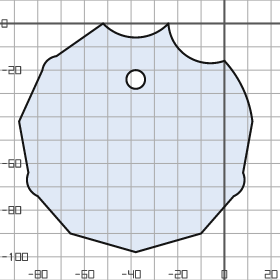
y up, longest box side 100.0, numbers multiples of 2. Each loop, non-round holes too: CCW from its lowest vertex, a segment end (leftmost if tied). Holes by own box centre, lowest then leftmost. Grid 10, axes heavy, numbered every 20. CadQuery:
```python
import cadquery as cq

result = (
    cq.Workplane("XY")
    .moveTo(-38.0, -98.0)
    .lineTo(-10.0, -90.0)
    .lineTo(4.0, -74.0)
    .threePointArc((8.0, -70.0), (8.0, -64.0))
    .lineTo(12.0, -42.0)
    .threePointArc((8.0, -28.0), (0.0, -16.0))
    .threePointArc((-16.0, -14.0), (-24.0, 0.0))
    .threePointArc((-38.0, -6.0), (-52.0, 0.0))
    .lineTo(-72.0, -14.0)
    .threePointArc((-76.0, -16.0), (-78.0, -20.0))
    .lineTo(-88.0, -42.0)
    .lineTo(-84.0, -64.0)
    .threePointArc((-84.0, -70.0), (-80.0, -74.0))
    .lineTo(-66.0, -90.0)
    .close()
    .moveTo(-38.0, -24.0)
    .circle(4.0)
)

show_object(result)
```